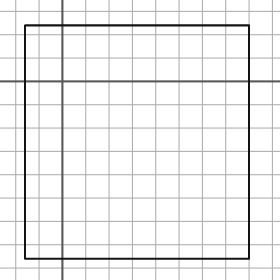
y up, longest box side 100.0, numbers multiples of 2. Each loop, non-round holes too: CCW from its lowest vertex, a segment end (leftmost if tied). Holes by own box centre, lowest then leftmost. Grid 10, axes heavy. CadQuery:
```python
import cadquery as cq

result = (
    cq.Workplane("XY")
    .moveTo(-16.0, -76.0)
    .lineTo(80.0, -76.0)
    .lineTo(80.0, 24.0)
    .lineTo(-16.0, 24.0)
    .close()
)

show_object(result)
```